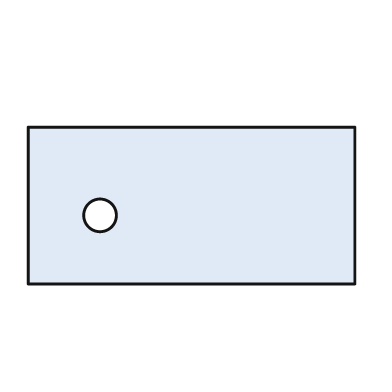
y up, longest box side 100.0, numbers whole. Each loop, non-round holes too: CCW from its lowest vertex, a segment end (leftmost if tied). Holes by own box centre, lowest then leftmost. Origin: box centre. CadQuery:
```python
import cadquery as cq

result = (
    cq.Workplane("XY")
    .moveTo(-50.0, -24.0)
    .lineTo(50.0, -24.0)
    .lineTo(50.0, 24.0)
    .lineTo(-50.0, 24.0)
    .close()
    .moveTo(-28.0, -3.0)
    .circle(5.0)
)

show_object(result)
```